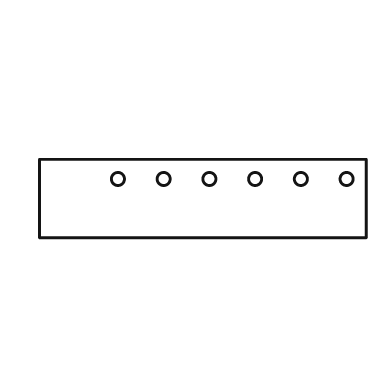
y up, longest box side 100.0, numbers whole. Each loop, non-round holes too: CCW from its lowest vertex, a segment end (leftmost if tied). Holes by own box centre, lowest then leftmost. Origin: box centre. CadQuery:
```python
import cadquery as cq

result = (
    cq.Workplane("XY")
    .moveTo(-50.0, -12.0)
    .lineTo(50.0, -12.0)
    .lineTo(50.0, 12.0)
    .lineTo(-50.0, 12.0)
    .close()
    .moveTo(-26.0, 6.0)
    .circle(2.0)
    .moveTo(-12.0, 6.0)
    .circle(2.0)
    .moveTo(2.0, 6.0)
    .circle(2.0)
    .moveTo(16.0, 6.0)
    .circle(2.0)
    .moveTo(30.0, 6.0)
    .circle(2.0)
    .moveTo(44.0, 6.0)
    .circle(2.0)
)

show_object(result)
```